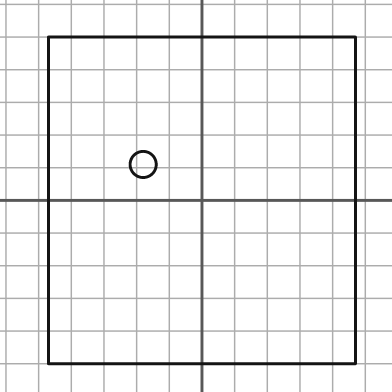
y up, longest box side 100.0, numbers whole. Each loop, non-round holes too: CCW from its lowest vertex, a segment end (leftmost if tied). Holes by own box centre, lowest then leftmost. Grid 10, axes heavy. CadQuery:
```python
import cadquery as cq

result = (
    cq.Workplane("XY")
    .moveTo(-47.0, -50.0)
    .lineTo(47.0, -50.0)
    .lineTo(47.0, 50.0)
    .lineTo(-47.0, 50.0)
    .close()
    .moveTo(-18.0, 11.0)
    .circle(4.0)
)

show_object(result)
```